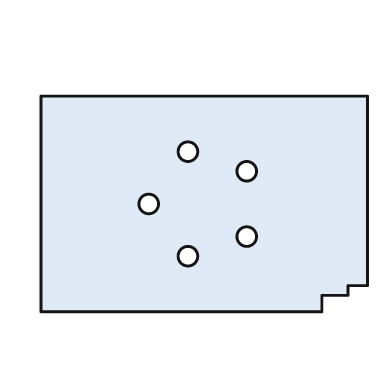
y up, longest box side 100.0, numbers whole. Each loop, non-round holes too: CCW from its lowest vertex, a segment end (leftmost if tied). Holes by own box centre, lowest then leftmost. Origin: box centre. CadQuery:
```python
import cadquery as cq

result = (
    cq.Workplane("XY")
    .moveTo(-50.0, -33.0)
    .lineTo(36.0, -33.0)
    .lineTo(36.0, -28.0)
    .lineTo(44.0, -28.0)
    .lineTo(44.0, -25.0)
    .lineTo(50.0, -25.0)
    .lineTo(50.0, 33.0)
    .lineTo(-50.0, 33.0)
    .close()
    .moveTo(-5.0, -16.0)
    .circle(3.0)
    .moveTo(13.0, -10.0)
    .circle(3.0)
    .moveTo(-17.0, 0.0)
    .circle(3.0)
    .moveTo(13.0, 10.0)
    .circle(3.0)
    .moveTo(-5.0, 16.0)
    .circle(3.0)
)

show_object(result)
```